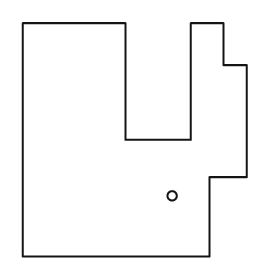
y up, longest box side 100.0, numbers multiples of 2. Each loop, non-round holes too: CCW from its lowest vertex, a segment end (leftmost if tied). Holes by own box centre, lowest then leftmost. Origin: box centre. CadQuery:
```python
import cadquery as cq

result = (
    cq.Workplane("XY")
    .moveTo(-48.0, -50.0)
    .lineTo(32.0, -50.0)
    .lineTo(32.0, -16.0)
    .lineTo(48.0, -16.0)
    .lineTo(48.0, 32.0)
    .lineTo(38.0, 32.0)
    .lineTo(38.0, 50.0)
    .lineTo(24.0, 50.0)
    .lineTo(24.0, 0.0)
    .lineTo(-4.0, 0.0)
    .lineTo(-4.0, 50.0)
    .lineTo(-48.0, 50.0)
    .close()
    .moveTo(16.0, -24.0)
    .circle(2.0)
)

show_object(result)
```